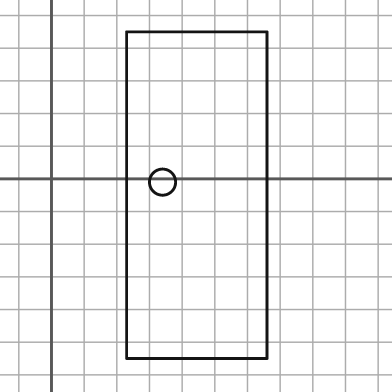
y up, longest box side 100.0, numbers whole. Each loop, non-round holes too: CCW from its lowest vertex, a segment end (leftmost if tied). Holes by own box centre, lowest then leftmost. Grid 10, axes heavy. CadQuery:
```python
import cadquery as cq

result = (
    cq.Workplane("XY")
    .moveTo(23.0, -55.0)
    .lineTo(66.0, -55.0)
    .lineTo(66.0, 45.0)
    .lineTo(23.0, 45.0)
    .close()
    .moveTo(34.0, -1.0)
    .circle(4.0)
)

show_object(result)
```